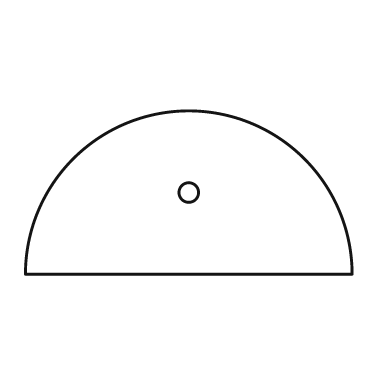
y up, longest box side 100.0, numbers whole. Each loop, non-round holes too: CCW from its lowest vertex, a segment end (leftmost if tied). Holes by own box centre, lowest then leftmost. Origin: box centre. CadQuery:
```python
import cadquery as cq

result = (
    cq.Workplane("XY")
    .moveTo(-50.0, -25.0)
    .lineTo(50.0, -25.0)
    .threePointArc((0.0, 25.0), (-50.0, -25.0))
    .close()
    .moveTo(0.0, 0.0)
    .circle(3.0)
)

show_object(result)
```